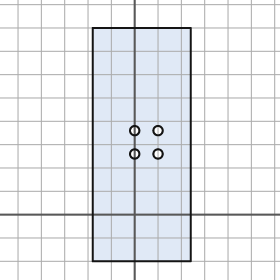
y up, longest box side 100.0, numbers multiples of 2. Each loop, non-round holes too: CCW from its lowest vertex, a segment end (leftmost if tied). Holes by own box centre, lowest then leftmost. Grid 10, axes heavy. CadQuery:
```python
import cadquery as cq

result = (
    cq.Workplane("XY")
    .moveTo(-18.0, -20.0)
    .lineTo(24.0, -20.0)
    .lineTo(24.0, 80.0)
    .lineTo(-18.0, 80.0)
    .close()
    .moveTo(0.0, 26.0)
    .circle(2.0)
    .moveTo(10.0, 26.0)
    .circle(2.0)
    .moveTo(0.0, 36.0)
    .circle(2.0)
    .moveTo(10.0, 36.0)
    .circle(2.0)
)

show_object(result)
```